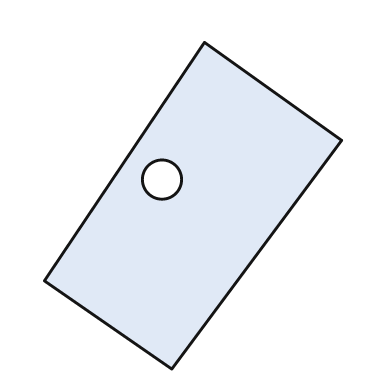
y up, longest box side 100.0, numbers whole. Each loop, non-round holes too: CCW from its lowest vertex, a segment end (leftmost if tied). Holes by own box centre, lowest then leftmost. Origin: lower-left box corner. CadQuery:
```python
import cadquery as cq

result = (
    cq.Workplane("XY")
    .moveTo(39.0, 0.0)
    .lineTo(91.0, 70.0)
    .lineTo(49.0, 100.0)
    .lineTo(0.0, 27.0)
    .close()
    .moveTo(36.0, 58.0)
    .circle(6.0)
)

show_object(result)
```